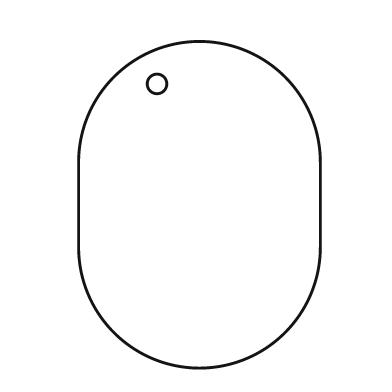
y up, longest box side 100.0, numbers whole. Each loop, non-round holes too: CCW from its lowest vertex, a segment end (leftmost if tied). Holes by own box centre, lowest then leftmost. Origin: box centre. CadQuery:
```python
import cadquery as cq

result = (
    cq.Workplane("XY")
    .moveTo(-37.0, -13.0)
    .threePointArc((0.0, -50.0), (37.0, -13.0))
    .lineTo(37.0, 13.0)
    .threePointArc((0.0, 50.0), (-37.0, 13.0))
    .close()
    .moveTo(-13.0, 37.0)
    .circle(3.0)
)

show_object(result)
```